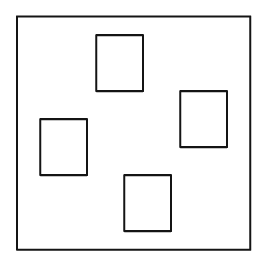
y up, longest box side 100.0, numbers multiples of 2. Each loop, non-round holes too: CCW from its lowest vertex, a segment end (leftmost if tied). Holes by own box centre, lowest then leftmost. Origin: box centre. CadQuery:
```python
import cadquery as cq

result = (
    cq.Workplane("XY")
    .moveTo(-50.0, -50.0)
    .lineTo(50.0, -50.0)
    .lineTo(50.0, 50.0)
    .lineTo(-50.0, 50.0)
    .close()
    .moveTo(-4.0, -42.0)
    .lineTo(16.0, -42.0)
    .lineTo(16.0, -18.0)
    .lineTo(-4.0, -18.0)
    .close()
    .moveTo(-40.0, -18.0)
    .lineTo(-20.0, -18.0)
    .lineTo(-20.0, 6.0)
    .lineTo(-40.0, 6.0)
    .close()
    .moveTo(20.0, -6.0)
    .lineTo(40.0, -6.0)
    .lineTo(40.0, 18.0)
    .lineTo(20.0, 18.0)
    .close()
    .moveTo(-16.0, 18.0)
    .lineTo(4.0, 18.0)
    .lineTo(4.0, 42.0)
    .lineTo(-16.0, 42.0)
    .close()
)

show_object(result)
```